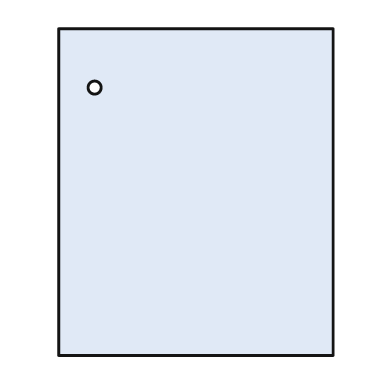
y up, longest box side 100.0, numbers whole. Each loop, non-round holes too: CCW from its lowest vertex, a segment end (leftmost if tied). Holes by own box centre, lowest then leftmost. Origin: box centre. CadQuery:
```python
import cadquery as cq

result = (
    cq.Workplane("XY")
    .moveTo(-42.0, -50.0)
    .lineTo(42.0, -50.0)
    .lineTo(42.0, 50.0)
    .lineTo(-42.0, 50.0)
    .close()
    .moveTo(-31.0, 32.0)
    .circle(2.0)
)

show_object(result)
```